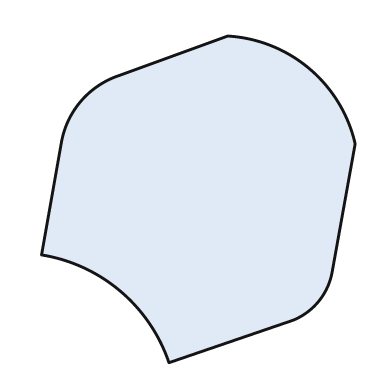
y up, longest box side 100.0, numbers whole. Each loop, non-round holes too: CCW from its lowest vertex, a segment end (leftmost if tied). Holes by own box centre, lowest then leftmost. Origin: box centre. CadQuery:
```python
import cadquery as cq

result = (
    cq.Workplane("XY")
    .moveTo(-9.0, -50.0)
    .lineTo(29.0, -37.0)
    .threePointArc((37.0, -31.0), (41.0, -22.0))
    .lineTo(48.0, 17.0)
    .threePointArc((34.0, 40.0), (9.0, 50.0))
    .lineTo(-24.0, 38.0)
    .threePointArc((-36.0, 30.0), (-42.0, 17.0))
    .lineTo(-48.0, -17.0)
    .threePointArc((-24.0, -28.0), (-9.0, -50.0))
    .close()
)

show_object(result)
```